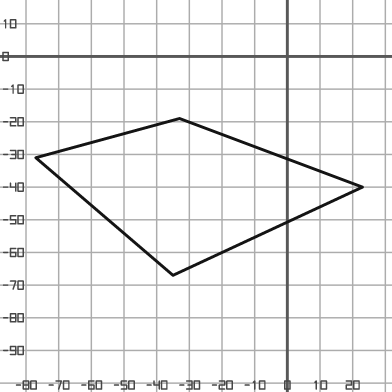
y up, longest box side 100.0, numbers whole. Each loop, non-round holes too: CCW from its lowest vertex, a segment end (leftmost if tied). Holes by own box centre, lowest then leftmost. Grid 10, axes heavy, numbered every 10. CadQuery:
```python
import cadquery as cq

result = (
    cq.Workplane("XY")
    .moveTo(-35.0, -67.0)
    .lineTo(23.0, -40.0)
    .lineTo(-33.0, -19.0)
    .lineTo(-77.0, -31.0)
    .close()
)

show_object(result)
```